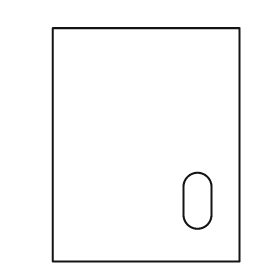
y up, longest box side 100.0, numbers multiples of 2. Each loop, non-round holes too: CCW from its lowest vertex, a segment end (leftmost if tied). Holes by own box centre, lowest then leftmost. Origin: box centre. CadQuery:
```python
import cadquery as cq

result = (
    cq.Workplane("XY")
    .moveTo(-40.0, -50.0)
    .lineTo(40.0, -50.0)
    .lineTo(40.0, 50.0)
    .lineTo(-40.0, 50.0)
    .close()
    .moveTo(16.0, -30.0)
    .threePointArc((22.0, -36.0), (28.0, -30.0))
    .lineTo(28.0, -18.0)
    .threePointArc((22.0, -12.0), (16.0, -18.0))
    .close()
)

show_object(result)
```